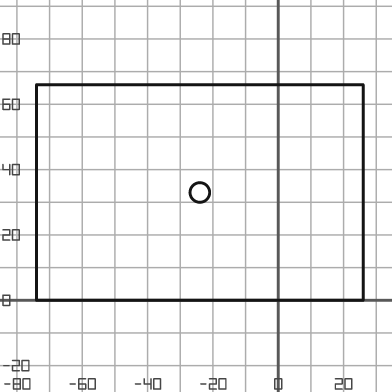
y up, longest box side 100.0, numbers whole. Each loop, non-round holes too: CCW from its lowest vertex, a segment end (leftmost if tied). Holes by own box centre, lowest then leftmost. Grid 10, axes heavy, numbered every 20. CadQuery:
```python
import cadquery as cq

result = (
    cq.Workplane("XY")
    .moveTo(-74.0, 0.0)
    .lineTo(26.0, 0.0)
    .lineTo(26.0, 66.0)
    .lineTo(-74.0, 66.0)
    .close()
    .moveTo(-24.0, 33.0)
    .circle(3.0)
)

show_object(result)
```